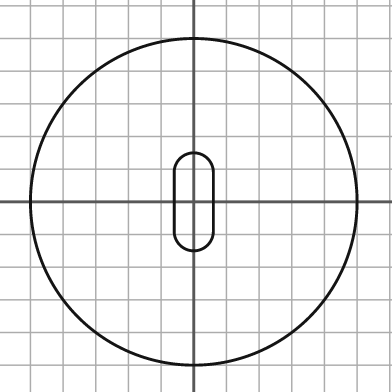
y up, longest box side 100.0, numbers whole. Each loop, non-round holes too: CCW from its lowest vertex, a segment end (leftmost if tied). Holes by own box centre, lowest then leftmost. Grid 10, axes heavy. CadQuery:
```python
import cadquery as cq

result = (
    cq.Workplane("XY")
    .moveTo(0.0, 0.0)
    .circle(50.0)
    .moveTo(-6.0, -9.0)
    .threePointArc((0.0, -15.0), (6.0, -9.0))
    .lineTo(6.0, 9.0)
    .threePointArc((0.0, 15.0), (-6.0, 9.0))
    .close()
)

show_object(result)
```